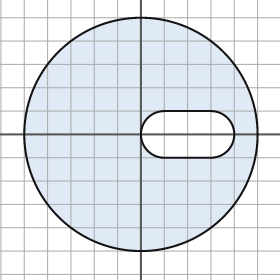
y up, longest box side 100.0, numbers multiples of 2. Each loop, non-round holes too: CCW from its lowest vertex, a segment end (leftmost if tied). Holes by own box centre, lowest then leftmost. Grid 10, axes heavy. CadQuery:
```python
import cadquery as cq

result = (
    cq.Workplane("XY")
    .moveTo(0.0, 0.0)
    .circle(50.0)
    .moveTo(10.0, -10.0)
    .lineTo(30.0, -10.0)
    .threePointArc((40.0, 0.0), (30.0, 10.0))
    .lineTo(10.0, 10.0)
    .threePointArc((0.0, 0.0), (10.0, -10.0))
    .close()
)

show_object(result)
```